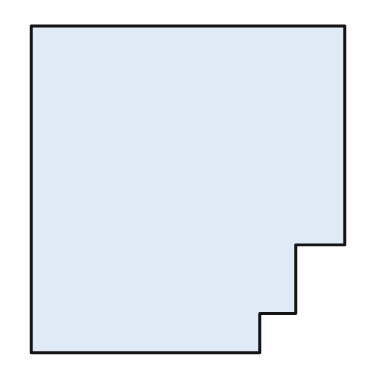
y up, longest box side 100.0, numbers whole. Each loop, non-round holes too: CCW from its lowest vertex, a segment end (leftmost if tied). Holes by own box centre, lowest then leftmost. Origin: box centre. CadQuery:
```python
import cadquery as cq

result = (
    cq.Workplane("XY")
    .moveTo(-48.0, -50.0)
    .lineTo(22.0, -50.0)
    .lineTo(22.0, -38.0)
    .lineTo(33.0, -38.0)
    .lineTo(33.0, -17.0)
    .lineTo(48.0, -17.0)
    .lineTo(48.0, 50.0)
    .lineTo(-48.0, 50.0)
    .close()
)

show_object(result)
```